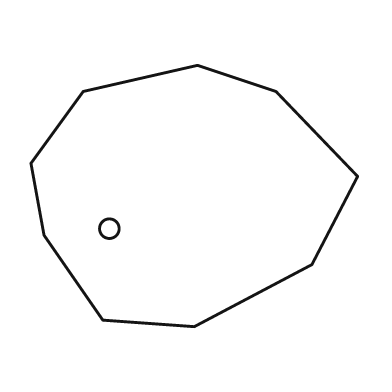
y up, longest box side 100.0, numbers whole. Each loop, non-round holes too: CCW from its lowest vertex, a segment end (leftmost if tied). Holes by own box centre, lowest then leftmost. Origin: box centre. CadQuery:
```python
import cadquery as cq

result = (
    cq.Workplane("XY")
    .moveTo(0.0, -40.0)
    .lineTo(36.0, -21.0)
    .lineTo(50.0, 6.0)
    .lineTo(25.0, 32.0)
    .lineTo(1.0, 40.0)
    .lineTo(-34.0, 32.0)
    .lineTo(-50.0, 10.0)
    .lineTo(-46.0, -12.0)
    .lineTo(-28.0, -38.0)
    .close()
    .moveTo(-26.0, -10.0)
    .circle(3.0)
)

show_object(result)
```